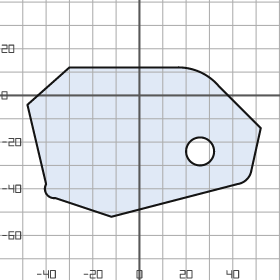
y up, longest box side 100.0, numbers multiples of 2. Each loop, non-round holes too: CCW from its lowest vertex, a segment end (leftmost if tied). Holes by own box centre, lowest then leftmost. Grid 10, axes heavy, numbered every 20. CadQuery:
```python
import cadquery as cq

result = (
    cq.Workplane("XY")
    .moveTo(-12.0, -52.0)
    .lineTo(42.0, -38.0)
    .threePointArc((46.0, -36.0), (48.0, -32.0))
    .lineTo(52.0, -14.0)
    .lineTo(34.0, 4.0)
    .threePointArc((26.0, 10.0), (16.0, 12.0))
    .lineTo(-30.0, 12.0)
    .lineTo(-48.0, -4.0)
    .lineTo(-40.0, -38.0)
    .threePointArc((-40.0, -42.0), (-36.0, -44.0))
    .close()
    .moveTo(26.0, -24.0)
    .circle(6.0)
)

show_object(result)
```